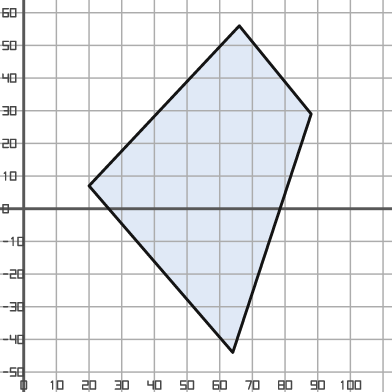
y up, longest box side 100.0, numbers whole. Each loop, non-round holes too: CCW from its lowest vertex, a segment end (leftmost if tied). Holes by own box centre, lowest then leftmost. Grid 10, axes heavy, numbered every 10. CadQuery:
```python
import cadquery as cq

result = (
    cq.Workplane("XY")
    .moveTo(64.0, -44.0)
    .lineTo(88.0, 29.0)
    .lineTo(66.0, 56.0)
    .lineTo(20.0, 7.0)
    .close()
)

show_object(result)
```